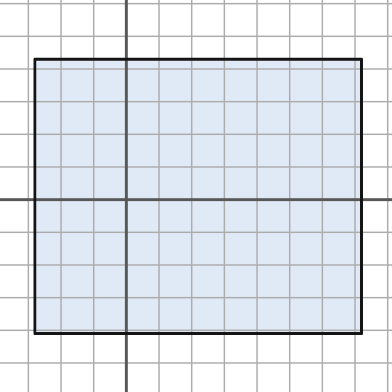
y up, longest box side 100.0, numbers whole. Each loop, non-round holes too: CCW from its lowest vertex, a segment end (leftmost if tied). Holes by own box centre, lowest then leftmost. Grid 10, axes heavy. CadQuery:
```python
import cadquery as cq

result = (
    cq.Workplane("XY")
    .moveTo(-28.0, -41.0)
    .lineTo(72.0, -41.0)
    .lineTo(72.0, 43.0)
    .lineTo(-28.0, 43.0)
    .close()
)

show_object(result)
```